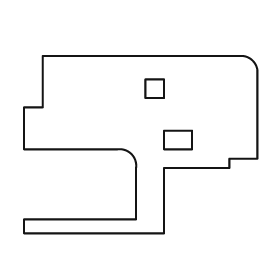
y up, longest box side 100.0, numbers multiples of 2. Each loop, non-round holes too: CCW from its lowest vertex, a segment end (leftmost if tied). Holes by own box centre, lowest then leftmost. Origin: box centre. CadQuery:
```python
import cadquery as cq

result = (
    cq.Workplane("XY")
    .moveTo(-50.0, -38.0)
    .lineTo(10.0, -38.0)
    .lineTo(10.0, -10.0)
    .lineTo(38.0, -10.0)
    .lineTo(38.0, -6.0)
    .lineTo(50.0, -6.0)
    .lineTo(50.0, 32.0)
    .threePointArc((48.0, 36.0), (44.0, 38.0))
    .lineTo(-42.0, 38.0)
    .lineTo(-42.0, 16.0)
    .lineTo(-50.0, 16.0)
    .lineTo(-50.0, -2.0)
    .lineTo(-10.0, -2.0)
    .threePointArc((-4.0, -4.0), (-2.0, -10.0))
    .lineTo(-2.0, -32.0)
    .lineTo(-50.0, -32.0)
    .close()
    .moveTo(10.0, -2.0)
    .lineTo(22.0, -2.0)
    .lineTo(22.0, 6.0)
    .lineTo(10.0, 6.0)
    .close()
    .moveTo(2.0, 20.0)
    .lineTo(10.0, 20.0)
    .lineTo(10.0, 28.0)
    .lineTo(2.0, 28.0)
    .close()
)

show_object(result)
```